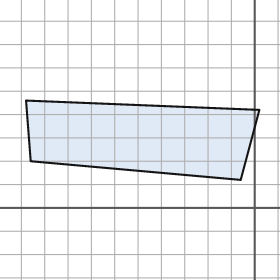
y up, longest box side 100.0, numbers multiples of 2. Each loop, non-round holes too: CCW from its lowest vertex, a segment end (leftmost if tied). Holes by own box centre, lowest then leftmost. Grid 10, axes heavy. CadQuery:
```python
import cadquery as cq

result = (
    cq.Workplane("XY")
    .moveTo(-6.0, 12.0)
    .lineTo(2.0, 42.0)
    .lineTo(-98.0, 46.0)
    .lineTo(-96.0, 20.0)
    .close()
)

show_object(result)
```